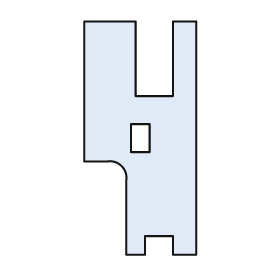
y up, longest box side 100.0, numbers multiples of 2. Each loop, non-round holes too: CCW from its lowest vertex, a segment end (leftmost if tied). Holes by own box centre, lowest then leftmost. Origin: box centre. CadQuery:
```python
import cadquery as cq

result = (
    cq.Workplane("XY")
    .moveTo(-6.0, -50.0)
    .lineTo(2.0, -50.0)
    .lineTo(2.0, -42.0)
    .lineTo(14.0, -42.0)
    .lineTo(14.0, -50.0)
    .lineTo(24.0, -50.0)
    .lineTo(24.0, 50.0)
    .lineTo(14.0, 50.0)
    .lineTo(14.0, 18.0)
    .lineTo(-2.0, 18.0)
    .lineTo(-2.0, 50.0)
    .lineTo(-24.0, 50.0)
    .lineTo(-24.0, -10.0)
    .lineTo(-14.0, -10.0)
    .threePointArc((-8.0, -12.0), (-6.0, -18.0))
    .close()
    .moveTo(-4.0, -6.0)
    .lineTo(4.0, -6.0)
    .lineTo(4.0, 6.0)
    .lineTo(-4.0, 6.0)
    .close()
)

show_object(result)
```